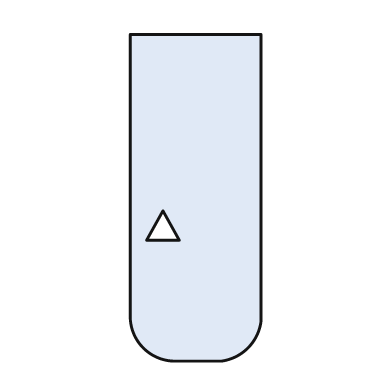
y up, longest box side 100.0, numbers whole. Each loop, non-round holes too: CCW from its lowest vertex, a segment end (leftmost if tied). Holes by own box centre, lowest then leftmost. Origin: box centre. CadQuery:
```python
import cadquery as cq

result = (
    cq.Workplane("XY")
    .moveTo(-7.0, -50.0)
    .lineTo(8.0, -50.0)
    .threePointArc((16.0, -46.0), (20.0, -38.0))
    .lineTo(20.0, 50.0)
    .lineTo(-20.0, 50.0)
    .lineTo(-20.0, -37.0)
    .threePointArc((-16.0, -46.0), (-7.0, -50.0))
    .close()
    .moveTo(-15.0, -13.0)
    .lineTo(-5.0, -13.0)
    .lineTo(-10.0, -4.0)
    .close()
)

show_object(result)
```